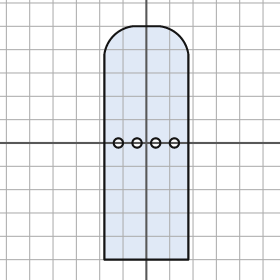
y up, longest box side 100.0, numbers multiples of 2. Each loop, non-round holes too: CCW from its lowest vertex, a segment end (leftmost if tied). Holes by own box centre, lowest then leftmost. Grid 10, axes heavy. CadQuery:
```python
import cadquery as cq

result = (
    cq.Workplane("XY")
    .moveTo(-18.0, -50.0)
    .lineTo(18.0, -50.0)
    .lineTo(18.0, 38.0)
    .threePointArc((14.0, 46.0), (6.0, 50.0))
    .lineTo(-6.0, 50.0)
    .threePointArc((-14.0, 46.0), (-18.0, 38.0))
    .close()
    .moveTo(-12.0, 0.0)
    .circle(2.0)
    .moveTo(-4.0, 0.0)
    .circle(2.0)
    .moveTo(4.0, 0.0)
    .circle(2.0)
    .moveTo(12.0, 0.0)
    .circle(2.0)
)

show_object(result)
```